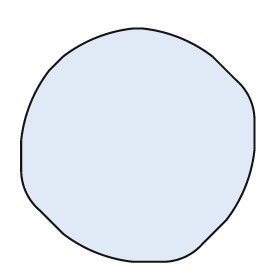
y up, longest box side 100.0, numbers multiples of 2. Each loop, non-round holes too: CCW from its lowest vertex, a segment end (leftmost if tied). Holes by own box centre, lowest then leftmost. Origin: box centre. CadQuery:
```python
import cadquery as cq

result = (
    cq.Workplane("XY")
    .moveTo(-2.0, -50.0)
    .lineTo(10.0, -50.0)
    .threePointArc((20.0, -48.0), (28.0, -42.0))
    .lineTo(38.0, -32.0)
    .threePointArc((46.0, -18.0), (50.0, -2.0))
    .lineTo(50.0, 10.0)
    .threePointArc((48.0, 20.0), (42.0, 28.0))
    .lineTo(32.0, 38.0)
    .threePointArc((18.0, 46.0), (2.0, 50.0))
    .lineTo(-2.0, 50.0)
    .threePointArc((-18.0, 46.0), (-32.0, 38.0))
    .lineTo(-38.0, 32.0)
    .threePointArc((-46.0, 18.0), (-50.0, 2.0))
    .lineTo(-50.0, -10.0)
    .threePointArc((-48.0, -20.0), (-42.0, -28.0))
    .lineTo(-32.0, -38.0)
    .threePointArc((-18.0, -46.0), (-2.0, -50.0))
    .close()
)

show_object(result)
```